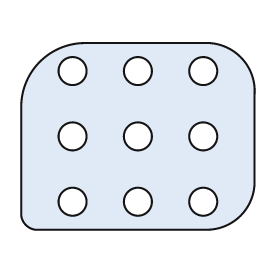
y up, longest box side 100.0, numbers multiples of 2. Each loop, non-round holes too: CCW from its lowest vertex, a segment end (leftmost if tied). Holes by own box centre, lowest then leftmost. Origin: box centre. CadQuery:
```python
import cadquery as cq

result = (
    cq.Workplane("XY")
    .moveTo(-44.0, -40.0)
    .lineTo(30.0, -40.0)
    .threePointArc((44.0, -34.0), (50.0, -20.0))
    .lineTo(50.0, 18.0)
    .threePointArc((44.0, 34.0), (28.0, 40.0))
    .lineTo(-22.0, 40.0)
    .threePointArc((-42.0, 32.0), (-50.0, 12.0))
    .lineTo(-50.0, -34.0)
    .threePointArc((-48.0, -38.0), (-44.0, -40.0))
    .close()
    .moveTo(-28.0, -28.0)
    .circle(6.0)
    .moveTo(0.0, -28.0)
    .circle(6.0)
    .moveTo(28.0, -28.0)
    .circle(6.0)
    .moveTo(-28.0, 0.0)
    .circle(6.0)
    .moveTo(0.0, 0.0)
    .circle(6.0)
    .moveTo(28.0, 0.0)
    .circle(6.0)
    .moveTo(-28.0, 28.0)
    .circle(6.0)
    .moveTo(0.0, 28.0)
    .circle(6.0)
    .moveTo(28.0, 28.0)
    .circle(6.0)
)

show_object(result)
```